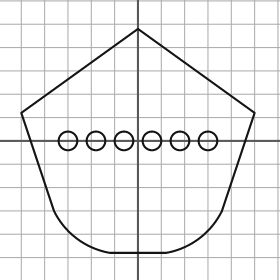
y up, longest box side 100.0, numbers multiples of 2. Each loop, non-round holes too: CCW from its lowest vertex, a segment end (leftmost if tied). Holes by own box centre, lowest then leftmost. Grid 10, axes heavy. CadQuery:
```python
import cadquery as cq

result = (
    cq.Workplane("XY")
    .moveTo(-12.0, -48.0)
    .lineTo(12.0, -48.0)
    .threePointArc((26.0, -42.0), (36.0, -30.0))
    .lineTo(50.0, 12.0)
    .lineTo(0.0, 48.0)
    .lineTo(-50.0, 12.0)
    .lineTo(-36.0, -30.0)
    .threePointArc((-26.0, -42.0), (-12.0, -48.0))
    .close()
    .moveTo(-30.0, 0.0)
    .circle(4.0)
    .moveTo(-18.0, 0.0)
    .circle(4.0)
    .moveTo(-6.0, 0.0)
    .circle(4.0)
    .moveTo(6.0, 0.0)
    .circle(4.0)
    .moveTo(18.0, 0.0)
    .circle(4.0)
    .moveTo(30.0, 0.0)
    .circle(4.0)
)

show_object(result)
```